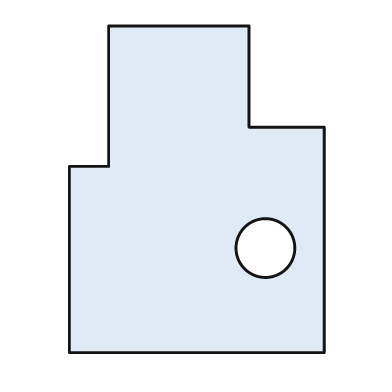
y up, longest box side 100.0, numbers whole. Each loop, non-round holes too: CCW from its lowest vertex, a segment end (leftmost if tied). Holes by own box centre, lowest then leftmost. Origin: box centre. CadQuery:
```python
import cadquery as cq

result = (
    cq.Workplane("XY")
    .moveTo(-39.0, -50.0)
    .lineTo(39.0, -50.0)
    .lineTo(39.0, 19.0)
    .lineTo(16.0, 19.0)
    .lineTo(16.0, 50.0)
    .lineTo(-27.0, 50.0)
    .lineTo(-27.0, 7.0)
    .lineTo(-39.0, 7.0)
    .close()
    .moveTo(21.0, -18.0)
    .circle(9.0)
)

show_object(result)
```